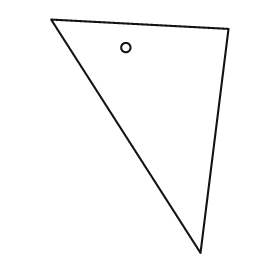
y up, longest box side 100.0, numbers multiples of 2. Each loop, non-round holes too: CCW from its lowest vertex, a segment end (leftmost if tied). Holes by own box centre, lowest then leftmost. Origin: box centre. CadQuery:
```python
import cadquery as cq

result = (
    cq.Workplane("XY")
    .moveTo(26.0, -50.0)
    .lineTo(38.0, 46.0)
    .lineTo(-38.0, 50.0)
    .close()
    .moveTo(-6.0, 38.0)
    .circle(2.0)
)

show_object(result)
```